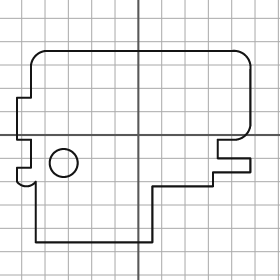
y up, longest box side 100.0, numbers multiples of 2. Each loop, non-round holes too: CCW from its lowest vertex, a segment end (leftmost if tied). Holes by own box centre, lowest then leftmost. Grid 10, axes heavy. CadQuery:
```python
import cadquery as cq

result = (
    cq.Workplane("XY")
    .moveTo(-44.0, -46.0)
    .lineTo(6.0, -46.0)
    .lineTo(6.0, -22.0)
    .lineTo(32.0, -22.0)
    .lineTo(32.0, -16.0)
    .lineTo(48.0, -16.0)
    .lineTo(48.0, -10.0)
    .lineTo(34.0, -10.0)
    .lineTo(34.0, -2.0)
    .lineTo(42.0, -2.0)
    .threePointArc((46.0, 0.0), (48.0, 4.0))
    .lineTo(48.0, 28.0)
    .threePointArc((46.0, 34.0), (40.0, 36.0))
    .lineTo(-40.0, 36.0)
    .threePointArc((-44.0, 34.0), (-46.0, 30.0))
    .lineTo(-46.0, 16.0)
    .lineTo(-52.0, 16.0)
    .lineTo(-52.0, -2.0)
    .lineTo(-46.0, -2.0)
    .lineTo(-46.0, -14.0)
    .lineTo(-52.0, -14.0)
    .lineTo(-52.0, -20.0)
    .threePointArc((-48.0, -22.0), (-44.0, -20.0))
    .close()
    .moveTo(-32.0, -12.0)
    .circle(6.0)
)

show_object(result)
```